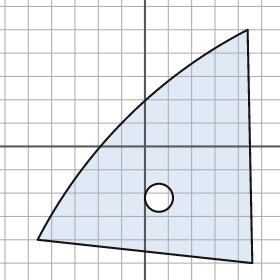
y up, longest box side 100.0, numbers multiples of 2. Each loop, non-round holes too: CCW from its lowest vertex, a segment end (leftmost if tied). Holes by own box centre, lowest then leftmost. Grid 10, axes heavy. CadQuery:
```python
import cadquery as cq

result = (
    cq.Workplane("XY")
    .moveTo(46.0, -50.0)
    .lineTo(44.0, 50.0)
    .threePointArc((-8.0, 12.0), (-46.0, -40.0))
    .close()
    .moveTo(6.0, -22.0)
    .circle(6.0)
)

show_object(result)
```